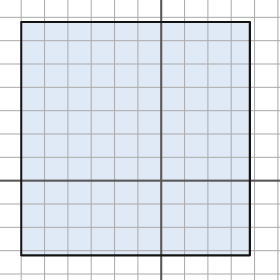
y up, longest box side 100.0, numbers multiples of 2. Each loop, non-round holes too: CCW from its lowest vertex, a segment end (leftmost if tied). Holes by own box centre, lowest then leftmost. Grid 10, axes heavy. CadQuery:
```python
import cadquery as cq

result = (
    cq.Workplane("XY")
    .moveTo(-60.0, -32.0)
    .lineTo(38.0, -32.0)
    .lineTo(38.0, 68.0)
    .lineTo(-60.0, 68.0)
    .close()
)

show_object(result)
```